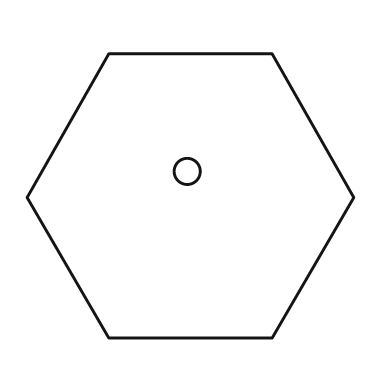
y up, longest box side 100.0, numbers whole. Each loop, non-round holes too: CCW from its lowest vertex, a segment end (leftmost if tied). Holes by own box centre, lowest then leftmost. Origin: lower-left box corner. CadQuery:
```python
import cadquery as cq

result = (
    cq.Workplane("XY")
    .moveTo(25.0, 0.0)
    .lineTo(75.0, 0.0)
    .lineTo(100.0, 43.0)
    .lineTo(75.0, 87.0)
    .lineTo(25.0, 87.0)
    .lineTo(0.0, 43.0)
    .close()
    .moveTo(49.0, 51.0)
    .circle(4.0)
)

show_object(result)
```